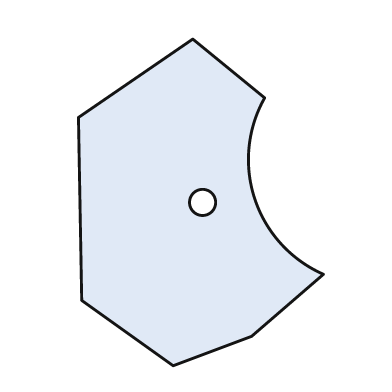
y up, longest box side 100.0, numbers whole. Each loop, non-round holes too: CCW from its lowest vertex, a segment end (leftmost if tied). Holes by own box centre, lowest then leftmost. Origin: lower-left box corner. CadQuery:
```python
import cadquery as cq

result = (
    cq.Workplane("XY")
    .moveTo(29.0, 0.0)
    .lineTo(53.0, 9.0)
    .lineTo(75.0, 28.0)
    .threePointArc((54.0, 51.0), (57.0, 82.0))
    .lineTo(35.0, 100.0)
    .lineTo(0.0, 76.0)
    .lineTo(1.0, 20.0)
    .close()
    .moveTo(38.0, 50.0)
    .circle(4.0)
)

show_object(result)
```